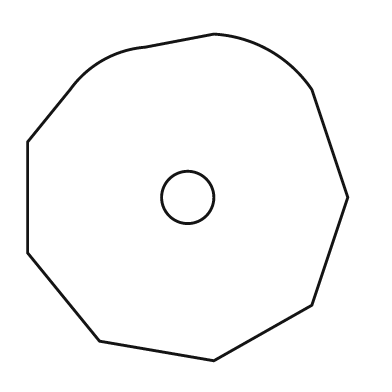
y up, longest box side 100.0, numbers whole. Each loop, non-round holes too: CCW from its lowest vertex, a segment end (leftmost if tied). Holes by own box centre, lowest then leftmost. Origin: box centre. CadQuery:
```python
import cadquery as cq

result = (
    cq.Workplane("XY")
    .moveTo(8.0, -50.0)
    .lineTo(38.0, -33.0)
    .lineTo(49.0, 0.0)
    .lineTo(38.0, 33.0)
    .threePointArc((25.0, 45.0), (8.0, 50.0))
    .lineTo(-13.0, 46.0)
    .threePointArc((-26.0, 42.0), (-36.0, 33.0))
    .lineTo(-49.0, 17.0)
    .lineTo(-49.0, -17.0)
    .lineTo(-27.0, -44.0)
    .close()
    .moveTo(0.0, 0.0)
    .circle(8.0)
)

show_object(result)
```